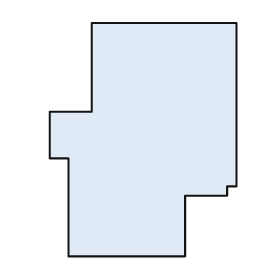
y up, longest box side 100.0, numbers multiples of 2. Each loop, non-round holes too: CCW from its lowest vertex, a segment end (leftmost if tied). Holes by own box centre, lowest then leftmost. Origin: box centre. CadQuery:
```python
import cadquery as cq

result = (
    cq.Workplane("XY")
    .moveTo(-32.0, -50.0)
    .lineTo(18.0, -50.0)
    .lineTo(18.0, -24.0)
    .lineTo(36.0, -24.0)
    .lineTo(36.0, -20.0)
    .lineTo(40.0, -20.0)
    .lineTo(40.0, 50.0)
    .lineTo(-22.0, 50.0)
    .lineTo(-22.0, 12.0)
    .lineTo(-40.0, 12.0)
    .lineTo(-40.0, -8.0)
    .lineTo(-32.0, -8.0)
    .close()
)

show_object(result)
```